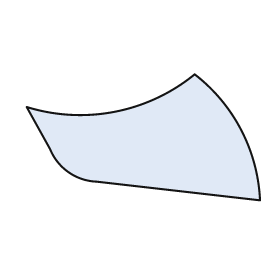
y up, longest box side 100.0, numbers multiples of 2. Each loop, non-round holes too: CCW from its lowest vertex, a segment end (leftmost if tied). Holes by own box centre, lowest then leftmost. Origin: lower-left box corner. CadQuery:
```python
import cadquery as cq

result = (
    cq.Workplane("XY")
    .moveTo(100.0, 0.0)
    .threePointArc((92.0, 30.0), (72.0, 54.0))
    .threePointArc((38.0, 38.0), (0.0, 40.0))
    .lineTo(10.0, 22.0)
    .threePointArc((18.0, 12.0), (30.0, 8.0))
    .close()
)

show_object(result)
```